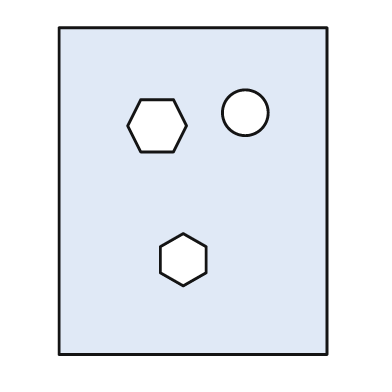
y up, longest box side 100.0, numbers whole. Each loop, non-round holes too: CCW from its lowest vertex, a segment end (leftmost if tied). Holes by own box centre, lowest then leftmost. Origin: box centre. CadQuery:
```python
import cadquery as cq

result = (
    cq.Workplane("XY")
    .moveTo(-41.0, -50.0)
    .lineTo(41.0, -50.0)
    .lineTo(41.0, 50.0)
    .lineTo(-41.0, 50.0)
    .close()
    .moveTo(-3.0, -29.0)
    .lineTo(4.0, -25.0)
    .lineTo(4.0, -17.0)
    .lineTo(-3.0, -13.0)
    .lineTo(-10.0, -17.0)
    .lineTo(-10.0, -25.0)
    .close()
    .moveTo(-16.0, 12.0)
    .lineTo(-6.0, 12.0)
    .lineTo(-2.0, 20.0)
    .lineTo(-6.0, 28.0)
    .lineTo(-16.0, 28.0)
    .lineTo(-20.0, 20.0)
    .close()
    .moveTo(16.0, 24.0)
    .circle(7.0)
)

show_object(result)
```